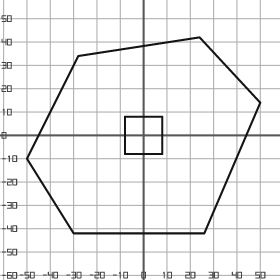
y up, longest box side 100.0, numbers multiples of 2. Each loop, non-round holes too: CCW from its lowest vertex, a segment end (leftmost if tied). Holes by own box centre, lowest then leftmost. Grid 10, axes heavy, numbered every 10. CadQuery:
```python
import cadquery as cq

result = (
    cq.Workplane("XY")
    .moveTo(-30.0, -42.0)
    .lineTo(26.0, -42.0)
    .lineTo(50.0, 14.0)
    .lineTo(24.0, 42.0)
    .lineTo(-28.0, 34.0)
    .lineTo(-50.0, -10.0)
    .close()
    .moveTo(-8.0, -8.0)
    .lineTo(8.0, -8.0)
    .lineTo(8.0, 8.0)
    .lineTo(-8.0, 8.0)
    .close()
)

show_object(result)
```